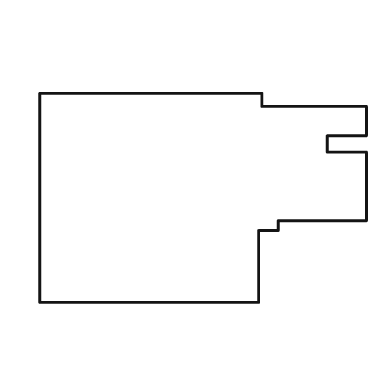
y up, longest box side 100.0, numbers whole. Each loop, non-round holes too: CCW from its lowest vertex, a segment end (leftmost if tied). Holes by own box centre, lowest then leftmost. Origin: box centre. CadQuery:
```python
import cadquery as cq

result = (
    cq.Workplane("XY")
    .moveTo(-50.0, -32.0)
    .lineTo(17.0, -32.0)
    .lineTo(17.0, -10.0)
    .lineTo(23.0, -10.0)
    .lineTo(23.0, -7.0)
    .lineTo(50.0, -7.0)
    .lineTo(50.0, 14.0)
    .lineTo(38.0, 14.0)
    .lineTo(38.0, 19.0)
    .lineTo(50.0, 19.0)
    .lineTo(50.0, 28.0)
    .lineTo(18.0, 28.0)
    .lineTo(18.0, 32.0)
    .lineTo(-50.0, 32.0)
    .close()
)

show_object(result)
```